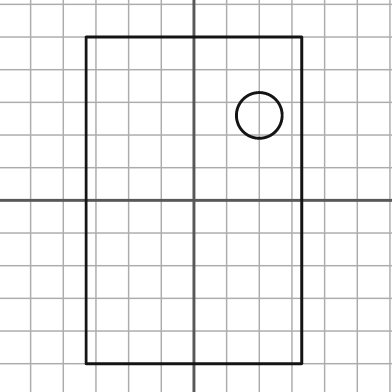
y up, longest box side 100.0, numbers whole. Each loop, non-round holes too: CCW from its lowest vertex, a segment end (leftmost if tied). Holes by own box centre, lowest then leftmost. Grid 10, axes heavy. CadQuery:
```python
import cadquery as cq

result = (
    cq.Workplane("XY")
    .moveTo(-33.0, -50.0)
    .lineTo(33.0, -50.0)
    .lineTo(33.0, 50.0)
    .lineTo(-33.0, 50.0)
    .close()
    .moveTo(20.0, 26.0)
    .circle(7.0)
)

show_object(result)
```